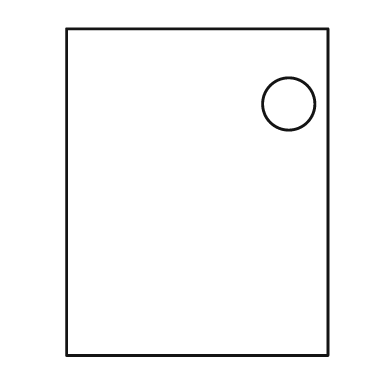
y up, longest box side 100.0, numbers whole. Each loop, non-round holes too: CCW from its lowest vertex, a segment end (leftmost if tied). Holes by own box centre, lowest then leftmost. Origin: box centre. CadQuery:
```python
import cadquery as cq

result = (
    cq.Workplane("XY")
    .moveTo(-40.0, -50.0)
    .lineTo(40.0, -50.0)
    .lineTo(40.0, 50.0)
    .lineTo(-40.0, 50.0)
    .close()
    .moveTo(28.0, 27.0)
    .circle(8.0)
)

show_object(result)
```